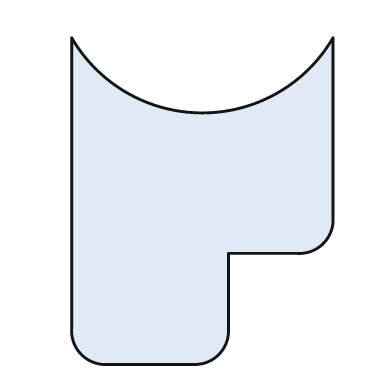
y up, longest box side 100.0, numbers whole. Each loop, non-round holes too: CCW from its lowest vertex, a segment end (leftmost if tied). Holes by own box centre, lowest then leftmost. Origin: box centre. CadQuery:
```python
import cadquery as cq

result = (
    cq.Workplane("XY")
    .moveTo(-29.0, -50.0)
    .lineTo(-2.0, -50.0)
    .threePointArc((5.0, -47.0), (8.0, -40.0))
    .lineTo(8.0, -16.0)
    .lineTo(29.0, -16.0)
    .threePointArc((37.0, -13.0), (40.0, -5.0))
    .lineTo(40.0, 50.0)
    .threePointArc((0.0, 27.0), (-40.0, 50.0))
    .lineTo(-40.0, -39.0)
    .threePointArc((-37.0, -47.0), (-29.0, -50.0))
    .close()
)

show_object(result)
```